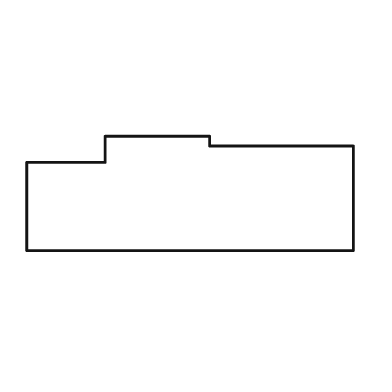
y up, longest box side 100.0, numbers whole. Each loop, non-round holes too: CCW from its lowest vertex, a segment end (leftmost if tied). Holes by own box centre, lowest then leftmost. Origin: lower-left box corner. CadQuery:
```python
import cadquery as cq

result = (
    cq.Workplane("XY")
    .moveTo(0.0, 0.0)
    .lineTo(100.0, 0.0)
    .lineTo(100.0, 32.0)
    .lineTo(56.0, 32.0)
    .lineTo(56.0, 35.0)
    .lineTo(24.0, 35.0)
    .lineTo(24.0, 27.0)
    .lineTo(0.0, 27.0)
    .close()
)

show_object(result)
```